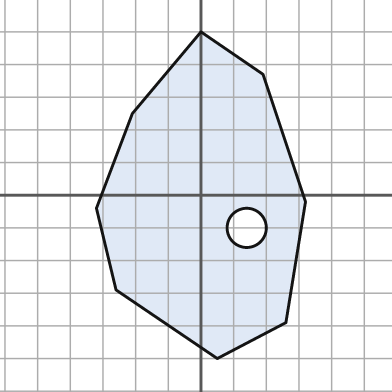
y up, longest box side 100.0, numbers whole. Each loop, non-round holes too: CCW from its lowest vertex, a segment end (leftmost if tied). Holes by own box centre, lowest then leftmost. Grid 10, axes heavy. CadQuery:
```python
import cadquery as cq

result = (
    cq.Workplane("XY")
    .moveTo(5.0, -50.0)
    .lineTo(26.0, -39.0)
    .lineTo(32.0, -2.0)
    .lineTo(19.0, 37.0)
    .lineTo(0.0, 50.0)
    .lineTo(-21.0, 25.0)
    .lineTo(-32.0, -4.0)
    .lineTo(-26.0, -29.0)
    .close()
    .moveTo(14.0, -10.0)
    .circle(6.0)
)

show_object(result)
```